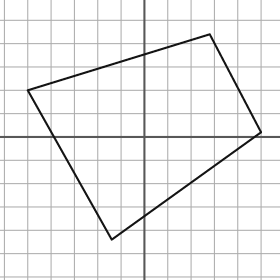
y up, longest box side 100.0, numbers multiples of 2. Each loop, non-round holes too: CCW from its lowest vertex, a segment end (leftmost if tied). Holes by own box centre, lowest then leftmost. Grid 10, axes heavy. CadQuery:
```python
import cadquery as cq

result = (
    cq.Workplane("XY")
    .moveTo(-14.0, -44.0)
    .lineTo(50.0, 2.0)
    .lineTo(28.0, 44.0)
    .lineTo(-50.0, 20.0)
    .close()
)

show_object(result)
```